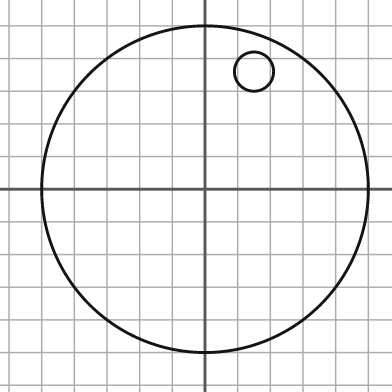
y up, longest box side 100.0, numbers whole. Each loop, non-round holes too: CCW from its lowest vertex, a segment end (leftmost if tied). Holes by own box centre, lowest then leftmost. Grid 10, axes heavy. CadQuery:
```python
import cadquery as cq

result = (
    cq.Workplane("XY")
    .moveTo(0.0, 0.0)
    .circle(50.0)
    .moveTo(15.0, 36.0)
    .circle(6.0)
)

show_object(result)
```